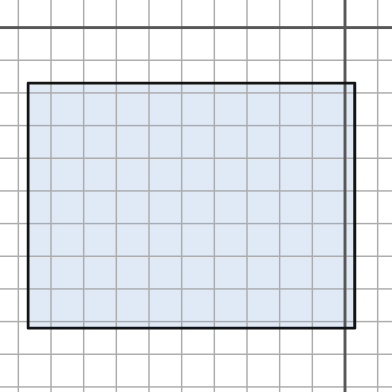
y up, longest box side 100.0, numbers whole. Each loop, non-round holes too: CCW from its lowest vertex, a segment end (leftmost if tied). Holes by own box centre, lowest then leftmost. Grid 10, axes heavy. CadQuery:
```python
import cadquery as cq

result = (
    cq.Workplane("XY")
    .moveTo(-97.0, -92.0)
    .lineTo(3.0, -92.0)
    .lineTo(3.0, -17.0)
    .lineTo(-97.0, -17.0)
    .close()
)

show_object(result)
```